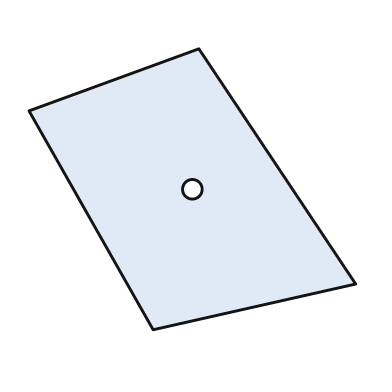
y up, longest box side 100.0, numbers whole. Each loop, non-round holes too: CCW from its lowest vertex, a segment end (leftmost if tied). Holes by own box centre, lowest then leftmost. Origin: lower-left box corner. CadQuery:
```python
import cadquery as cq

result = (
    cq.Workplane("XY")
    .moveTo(38.0, 0.0)
    .lineTo(100.0, 14.0)
    .lineTo(52.0, 86.0)
    .lineTo(0.0, 67.0)
    .close()
    .moveTo(50.0, 43.0)
    .circle(3.0)
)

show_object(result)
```